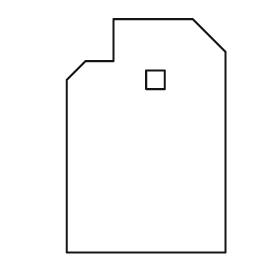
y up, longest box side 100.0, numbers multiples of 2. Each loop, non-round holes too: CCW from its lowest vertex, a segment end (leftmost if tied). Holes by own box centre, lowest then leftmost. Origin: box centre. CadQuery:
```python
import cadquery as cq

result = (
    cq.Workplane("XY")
    .moveTo(-34.0, -50.0)
    .lineTo(34.0, -50.0)
    .lineTo(34.0, 36.0)
    .lineTo(20.0, 50.0)
    .lineTo(-14.0, 50.0)
    .lineTo(-14.0, 32.0)
    .lineTo(-26.0, 32.0)
    .lineTo(-34.0, 24.0)
    .close()
    .moveTo(0.0, 20.0)
    .lineTo(8.0, 20.0)
    .lineTo(8.0, 28.0)
    .lineTo(0.0, 28.0)
    .close()
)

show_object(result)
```